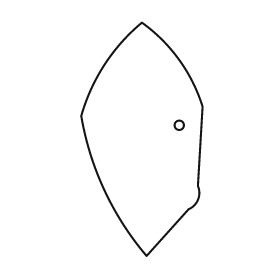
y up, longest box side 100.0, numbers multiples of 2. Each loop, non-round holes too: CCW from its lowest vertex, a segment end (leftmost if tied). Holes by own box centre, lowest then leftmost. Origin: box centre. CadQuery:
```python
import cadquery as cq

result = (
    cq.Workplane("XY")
    .moveTo(2.0, -50.0)
    .lineTo(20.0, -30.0)
    .threePointArc((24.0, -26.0), (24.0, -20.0))
    .lineTo(26.0, 14.0)
    .threePointArc((16.0, 34.0), (0.0, 50.0))
    .threePointArc((-16.0, 32.0), (-26.0, 10.0))
    .threePointArc((-16.0, -22.0), (2.0, -50.0))
    .close()
    .moveTo(16.0, 6.0)
    .circle(2.0)
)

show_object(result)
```